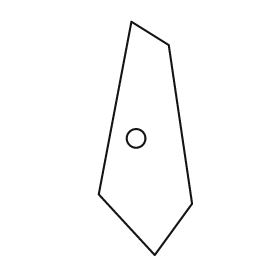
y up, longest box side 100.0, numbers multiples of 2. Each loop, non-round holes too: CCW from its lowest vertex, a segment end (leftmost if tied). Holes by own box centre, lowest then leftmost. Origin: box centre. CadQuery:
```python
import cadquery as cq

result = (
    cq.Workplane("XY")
    .moveTo(4.0, -50.0)
    .lineTo(20.0, -28.0)
    .lineTo(10.0, 40.0)
    .lineTo(-6.0, 50.0)
    .lineTo(-20.0, -24.0)
    .close()
    .moveTo(-4.0, 0.0)
    .circle(4.0)
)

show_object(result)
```